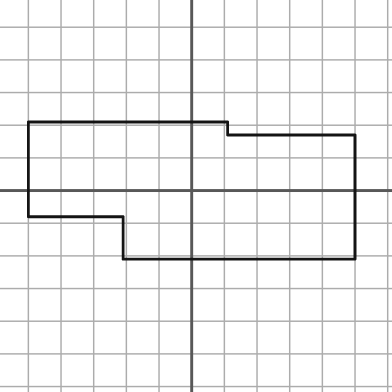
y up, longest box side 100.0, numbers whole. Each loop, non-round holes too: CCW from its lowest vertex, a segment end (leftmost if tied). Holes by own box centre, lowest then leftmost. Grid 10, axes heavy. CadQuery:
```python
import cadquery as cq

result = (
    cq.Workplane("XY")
    .moveTo(-21.0, -21.0)
    .lineTo(50.0, -21.0)
    .lineTo(50.0, 17.0)
    .lineTo(11.0, 17.0)
    .lineTo(11.0, 21.0)
    .lineTo(-50.0, 21.0)
    .lineTo(-50.0, -8.0)
    .lineTo(-21.0, -8.0)
    .close()
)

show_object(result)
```